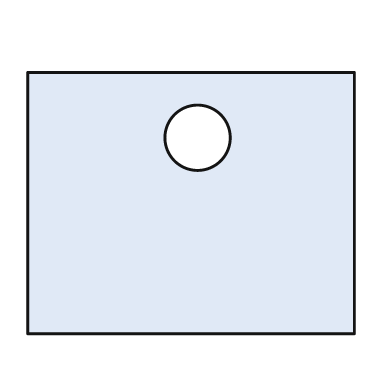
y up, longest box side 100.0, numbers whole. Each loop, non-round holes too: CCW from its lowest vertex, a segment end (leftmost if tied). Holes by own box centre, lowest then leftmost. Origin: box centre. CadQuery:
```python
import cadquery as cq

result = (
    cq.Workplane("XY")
    .moveTo(-50.0, -40.0)
    .lineTo(50.0, -40.0)
    .lineTo(50.0, 40.0)
    .lineTo(-50.0, 40.0)
    .close()
    .moveTo(2.0, 20.0)
    .circle(10.0)
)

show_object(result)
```